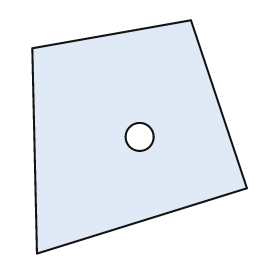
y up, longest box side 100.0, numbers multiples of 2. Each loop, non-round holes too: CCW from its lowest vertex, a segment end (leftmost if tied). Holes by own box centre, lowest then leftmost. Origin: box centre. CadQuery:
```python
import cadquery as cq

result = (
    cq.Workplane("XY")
    .moveTo(-44.0, -50.0)
    .lineTo(46.0, -22.0)
    .lineTo(22.0, 50.0)
    .lineTo(-46.0, 38.0)
    .close()
    .moveTo(0.0, 0.0)
    .circle(6.0)
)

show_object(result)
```